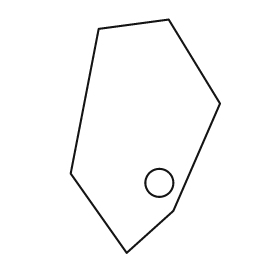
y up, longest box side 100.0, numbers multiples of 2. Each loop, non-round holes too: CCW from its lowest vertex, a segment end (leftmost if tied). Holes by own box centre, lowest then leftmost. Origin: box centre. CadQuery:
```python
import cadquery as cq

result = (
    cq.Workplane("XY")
    .moveTo(-8.0, -50.0)
    .lineTo(12.0, -32.0)
    .lineTo(32.0, 14.0)
    .lineTo(10.0, 50.0)
    .lineTo(-20.0, 46.0)
    .lineTo(-32.0, -16.0)
    .close()
    .moveTo(6.0, -20.0)
    .circle(6.0)
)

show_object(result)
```